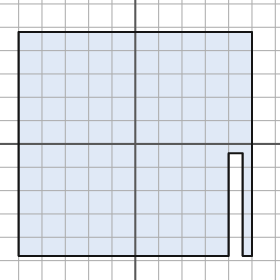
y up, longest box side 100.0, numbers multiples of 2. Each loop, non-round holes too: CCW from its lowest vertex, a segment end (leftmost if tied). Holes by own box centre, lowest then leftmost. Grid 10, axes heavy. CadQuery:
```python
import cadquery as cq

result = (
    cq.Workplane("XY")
    .moveTo(-50.0, -48.0)
    .lineTo(40.0, -48.0)
    .lineTo(40.0, -4.0)
    .lineTo(46.0, -4.0)
    .lineTo(46.0, -48.0)
    .lineTo(50.0, -48.0)
    .lineTo(50.0, 48.0)
    .lineTo(-50.0, 48.0)
    .close()
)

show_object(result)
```